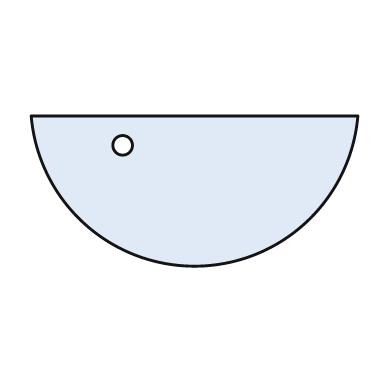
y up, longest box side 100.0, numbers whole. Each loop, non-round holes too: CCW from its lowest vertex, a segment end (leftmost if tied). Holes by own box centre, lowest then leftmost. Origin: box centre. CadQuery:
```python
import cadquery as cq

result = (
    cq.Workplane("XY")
    .moveTo(-50.0, 23.0)
    .threePointArc((0.0, -23.0), (50.0, 23.0))
    .close()
    .moveTo(-22.0, 14.0)
    .circle(3.0)
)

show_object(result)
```